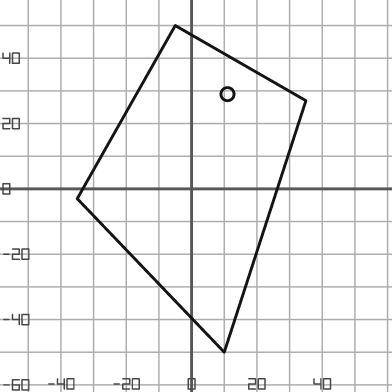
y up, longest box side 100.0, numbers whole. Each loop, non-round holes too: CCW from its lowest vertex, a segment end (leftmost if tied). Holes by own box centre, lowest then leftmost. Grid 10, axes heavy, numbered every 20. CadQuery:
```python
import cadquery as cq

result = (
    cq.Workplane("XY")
    .moveTo(10.0, -50.0)
    .lineTo(35.0, 27.0)
    .lineTo(-5.0, 50.0)
    .lineTo(-35.0, -3.0)
    .close()
    .moveTo(11.0, 29.0)
    .circle(2.0)
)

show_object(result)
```